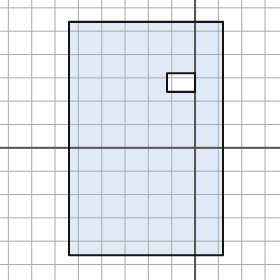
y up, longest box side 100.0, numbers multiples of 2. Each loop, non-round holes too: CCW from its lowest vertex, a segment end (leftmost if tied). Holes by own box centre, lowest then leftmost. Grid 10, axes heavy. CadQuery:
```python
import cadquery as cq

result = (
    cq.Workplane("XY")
    .moveTo(-54.0, -46.0)
    .lineTo(12.0, -46.0)
    .lineTo(12.0, 54.0)
    .lineTo(-54.0, 54.0)
    .close()
    .moveTo(-12.0, 24.0)
    .lineTo(0.0, 24.0)
    .lineTo(0.0, 32.0)
    .lineTo(-12.0, 32.0)
    .close()
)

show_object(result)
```